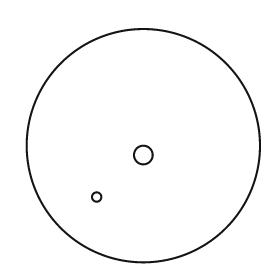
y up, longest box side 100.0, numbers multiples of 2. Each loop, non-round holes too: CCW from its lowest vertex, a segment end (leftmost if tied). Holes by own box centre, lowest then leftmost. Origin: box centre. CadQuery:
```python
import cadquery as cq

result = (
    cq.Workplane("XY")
    .moveTo(0.0, 0.0)
    .circle(50.0)
    .moveTo(-20.0, -22.0)
    .circle(2.0)
    .moveTo(0.0, -4.0)
    .circle(4.0)
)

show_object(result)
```